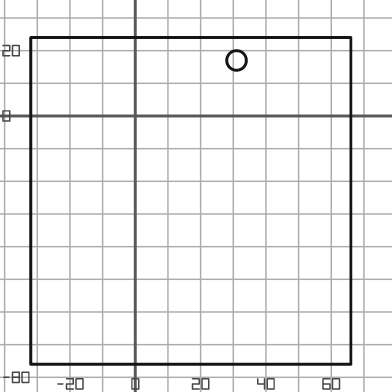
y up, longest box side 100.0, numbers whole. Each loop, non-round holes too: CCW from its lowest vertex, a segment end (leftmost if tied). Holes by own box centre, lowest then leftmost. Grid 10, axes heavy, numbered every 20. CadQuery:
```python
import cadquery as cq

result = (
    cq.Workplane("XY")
    .moveTo(-32.0, -76.0)
    .lineTo(66.0, -76.0)
    .lineTo(66.0, 24.0)
    .lineTo(-32.0, 24.0)
    .close()
    .moveTo(31.0, 17.0)
    .circle(3.0)
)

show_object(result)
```